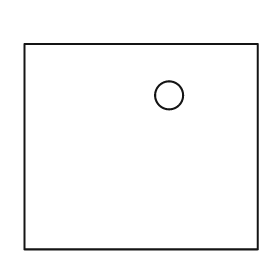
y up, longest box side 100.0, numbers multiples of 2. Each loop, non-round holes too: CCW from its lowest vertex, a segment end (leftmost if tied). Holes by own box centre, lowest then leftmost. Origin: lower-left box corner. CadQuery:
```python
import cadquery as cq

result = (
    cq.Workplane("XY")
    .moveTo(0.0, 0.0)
    .lineTo(100.0, 0.0)
    .lineTo(100.0, 88.0)
    .lineTo(0.0, 88.0)
    .close()
    .moveTo(62.0, 66.0)
    .circle(6.0)
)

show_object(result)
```